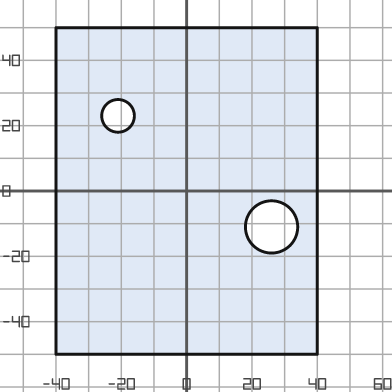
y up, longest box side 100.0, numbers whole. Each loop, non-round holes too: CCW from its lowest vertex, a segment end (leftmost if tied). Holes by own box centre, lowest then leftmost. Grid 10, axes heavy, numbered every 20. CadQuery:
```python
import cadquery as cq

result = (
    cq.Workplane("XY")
    .moveTo(-40.0, -50.0)
    .lineTo(40.0, -50.0)
    .lineTo(40.0, 50.0)
    .lineTo(-40.0, 50.0)
    .close()
    .moveTo(26.0, -11.0)
    .circle(8.0)
    .moveTo(-21.0, 23.0)
    .circle(5.0)
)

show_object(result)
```